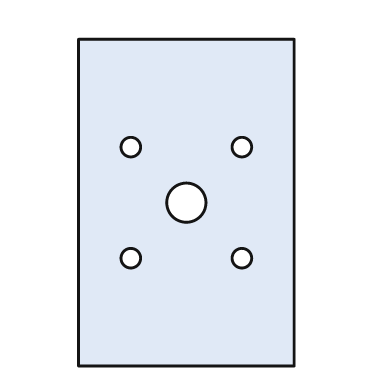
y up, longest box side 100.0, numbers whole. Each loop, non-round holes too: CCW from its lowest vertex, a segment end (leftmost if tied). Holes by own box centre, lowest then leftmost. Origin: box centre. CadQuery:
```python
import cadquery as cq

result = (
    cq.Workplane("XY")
    .moveTo(-33.0, -50.0)
    .lineTo(33.0, -50.0)
    .lineTo(33.0, 50.0)
    .lineTo(-33.0, 50.0)
    .close()
    .moveTo(-17.0, -17.0)
    .circle(3.0)
    .moveTo(17.0, -17.0)
    .circle(3.0)
    .moveTo(0.0, 0.0)
    .circle(6.0)
    .moveTo(-17.0, 17.0)
    .circle(3.0)
    .moveTo(17.0, 17.0)
    .circle(3.0)
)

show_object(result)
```